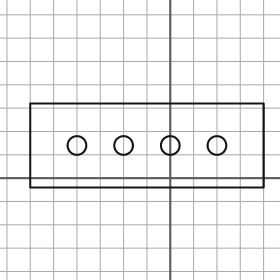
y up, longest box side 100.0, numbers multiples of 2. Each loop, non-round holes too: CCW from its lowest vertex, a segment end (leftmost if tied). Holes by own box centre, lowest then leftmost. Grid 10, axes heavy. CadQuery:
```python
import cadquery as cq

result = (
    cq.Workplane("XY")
    .moveTo(-60.0, -4.0)
    .lineTo(40.0, -4.0)
    .lineTo(40.0, 32.0)
    .lineTo(-60.0, 32.0)
    .close()
    .moveTo(-40.0, 14.0)
    .circle(4.0)
    .moveTo(-20.0, 14.0)
    .circle(4.0)
    .moveTo(0.0, 14.0)
    .circle(4.0)
    .moveTo(20.0, 14.0)
    .circle(4.0)
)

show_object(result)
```